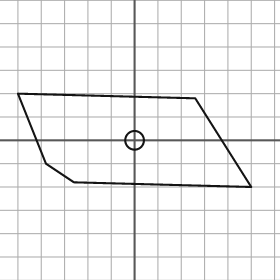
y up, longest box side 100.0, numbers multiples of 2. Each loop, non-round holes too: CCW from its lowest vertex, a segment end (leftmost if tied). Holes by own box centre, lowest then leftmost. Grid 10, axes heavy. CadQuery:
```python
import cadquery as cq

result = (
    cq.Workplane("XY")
    .moveTo(50.0, -20.0)
    .lineTo(26.0, 18.0)
    .lineTo(-50.0, 20.0)
    .lineTo(-38.0, -10.0)
    .lineTo(-26.0, -18.0)
    .close()
    .moveTo(0.0, 0.0)
    .circle(4.0)
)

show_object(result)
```